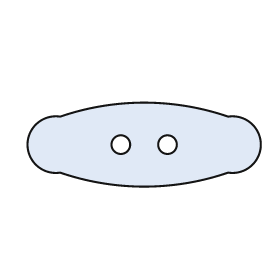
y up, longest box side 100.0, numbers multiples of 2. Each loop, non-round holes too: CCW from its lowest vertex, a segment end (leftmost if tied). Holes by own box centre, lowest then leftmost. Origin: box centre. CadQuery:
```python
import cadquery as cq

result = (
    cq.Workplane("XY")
    .moveTo(-36.0, -12.0)
    .threePointArc((0.0, -18.0), (36.0, -12.0))
    .threePointArc((50.0, 0.0), (36.0, 12.0))
    .threePointArc((0.0, 18.0), (-36.0, 12.0))
    .threePointArc((-50.0, 0.0), (-36.0, -12.0))
    .close()
    .moveTo(-10.0, 0.0)
    .circle(4.0)
    .moveTo(10.0, 0.0)
    .circle(4.0)
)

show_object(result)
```